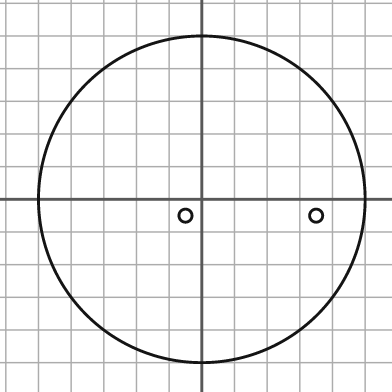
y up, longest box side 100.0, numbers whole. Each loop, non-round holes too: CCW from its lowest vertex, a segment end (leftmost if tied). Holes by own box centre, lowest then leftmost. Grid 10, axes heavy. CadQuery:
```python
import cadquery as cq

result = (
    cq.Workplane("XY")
    .moveTo(0.0, 0.0)
    .circle(50.0)
    .moveTo(-5.0, -5.0)
    .circle(2.0)
    .moveTo(35.0, -5.0)
    .circle(2.0)
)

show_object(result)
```